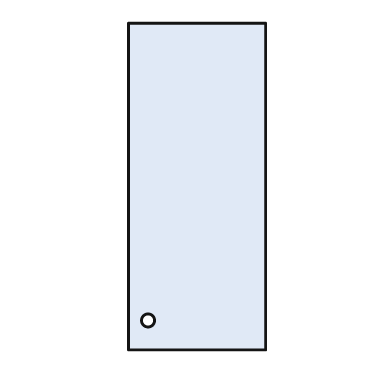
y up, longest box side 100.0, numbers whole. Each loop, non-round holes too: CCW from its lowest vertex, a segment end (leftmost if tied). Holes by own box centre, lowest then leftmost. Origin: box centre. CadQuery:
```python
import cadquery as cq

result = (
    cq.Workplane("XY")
    .moveTo(-21.0, -50.0)
    .lineTo(21.0, -50.0)
    .lineTo(21.0, 50.0)
    .lineTo(-21.0, 50.0)
    .close()
    .moveTo(-15.0, -41.0)
    .circle(2.0)
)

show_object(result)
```